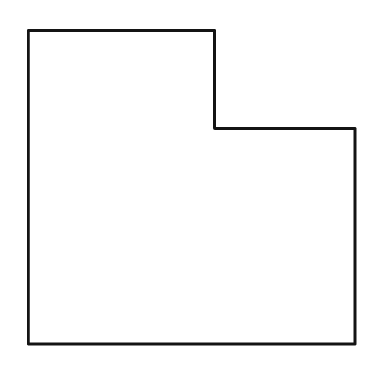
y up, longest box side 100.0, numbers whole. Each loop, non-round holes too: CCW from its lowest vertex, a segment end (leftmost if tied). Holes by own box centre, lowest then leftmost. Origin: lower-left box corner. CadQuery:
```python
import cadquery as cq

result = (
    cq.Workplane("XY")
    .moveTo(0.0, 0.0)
    .lineTo(100.0, 0.0)
    .lineTo(100.0, 66.0)
    .lineTo(57.0, 66.0)
    .lineTo(57.0, 96.0)
    .lineTo(0.0, 96.0)
    .close()
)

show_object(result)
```